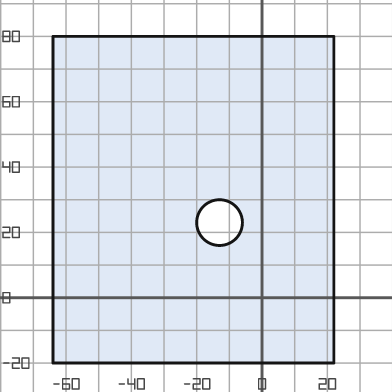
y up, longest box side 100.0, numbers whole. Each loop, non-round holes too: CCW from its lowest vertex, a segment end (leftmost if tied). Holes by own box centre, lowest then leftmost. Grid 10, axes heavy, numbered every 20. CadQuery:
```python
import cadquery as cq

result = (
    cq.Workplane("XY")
    .moveTo(-64.0, -20.0)
    .lineTo(22.0, -20.0)
    .lineTo(22.0, 80.0)
    .lineTo(-64.0, 80.0)
    .close()
    .moveTo(-13.0, 23.0)
    .circle(7.0)
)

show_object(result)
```